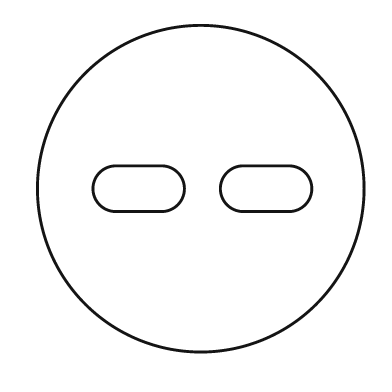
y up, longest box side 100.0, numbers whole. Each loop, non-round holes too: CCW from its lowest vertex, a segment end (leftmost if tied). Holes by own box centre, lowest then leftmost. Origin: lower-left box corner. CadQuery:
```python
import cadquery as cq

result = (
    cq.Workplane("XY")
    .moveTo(50.0, 50.0)
    .circle(50.0)
    .moveTo(24.0, 43.0)
    .lineTo(38.0, 43.0)
    .threePointArc((45.0, 50.0), (38.0, 57.0))
    .lineTo(24.0, 57.0)
    .threePointArc((17.0, 50.0), (24.0, 43.0))
    .close()
    .moveTo(63.0, 43.0)
    .lineTo(77.0, 43.0)
    .threePointArc((84.0, 50.0), (77.0, 57.0))
    .lineTo(63.0, 57.0)
    .threePointArc((56.0, 50.0), (63.0, 43.0))
    .close()
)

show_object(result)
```